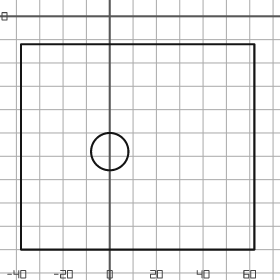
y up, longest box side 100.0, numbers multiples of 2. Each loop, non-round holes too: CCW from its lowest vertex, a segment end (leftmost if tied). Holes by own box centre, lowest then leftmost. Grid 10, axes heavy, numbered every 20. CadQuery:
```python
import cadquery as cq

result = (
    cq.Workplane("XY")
    .moveTo(-38.0, -100.0)
    .lineTo(62.0, -100.0)
    .lineTo(62.0, -12.0)
    .lineTo(-38.0, -12.0)
    .close()
    .moveTo(0.0, -58.0)
    .circle(8.0)
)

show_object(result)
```